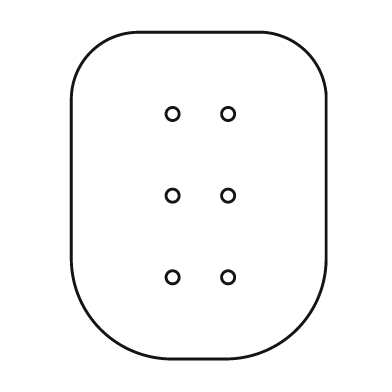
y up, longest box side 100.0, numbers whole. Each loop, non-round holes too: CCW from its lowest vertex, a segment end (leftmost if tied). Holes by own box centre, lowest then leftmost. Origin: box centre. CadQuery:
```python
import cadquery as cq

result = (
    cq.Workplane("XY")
    .moveTo(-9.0, -50.0)
    .lineTo(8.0, -50.0)
    .threePointArc((30.0, -41.0), (39.0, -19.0))
    .lineTo(39.0, 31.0)
    .threePointArc((33.0, 44.0), (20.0, 50.0))
    .lineTo(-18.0, 50.0)
    .threePointArc((-33.0, 44.0), (-39.0, 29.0))
    .lineTo(-39.0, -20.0)
    .threePointArc((-30.0, -41.0), (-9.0, -50.0))
    .close()
    .moveTo(-8.0, -25.0)
    .circle(2.0)
    .moveTo(9.0, -25.0)
    .circle(2.0)
    .moveTo(-8.0, 0.0)
    .circle(2.0)
    .moveTo(9.0, 0.0)
    .circle(2.0)
    .moveTo(-8.0, 25.0)
    .circle(2.0)
    .moveTo(9.0, 25.0)
    .circle(2.0)
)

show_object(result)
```